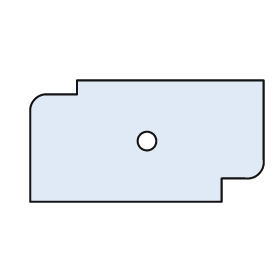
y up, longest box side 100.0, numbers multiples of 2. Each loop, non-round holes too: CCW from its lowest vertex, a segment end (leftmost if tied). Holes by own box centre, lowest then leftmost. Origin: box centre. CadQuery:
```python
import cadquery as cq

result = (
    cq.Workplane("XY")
    .moveTo(-50.0, -26.0)
    .lineTo(32.0, -26.0)
    .lineTo(32.0, -16.0)
    .lineTo(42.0, -16.0)
    .threePointArc((48.0, -14.0), (50.0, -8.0))
    .lineTo(50.0, 26.0)
    .lineTo(-30.0, 26.0)
    .lineTo(-30.0, 20.0)
    .lineTo(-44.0, 20.0)
    .threePointArc((-48.0, 18.0), (-50.0, 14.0))
    .close()
    .moveTo(0.0, 0.0)
    .circle(4.0)
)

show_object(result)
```